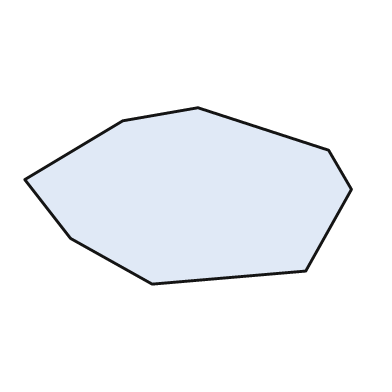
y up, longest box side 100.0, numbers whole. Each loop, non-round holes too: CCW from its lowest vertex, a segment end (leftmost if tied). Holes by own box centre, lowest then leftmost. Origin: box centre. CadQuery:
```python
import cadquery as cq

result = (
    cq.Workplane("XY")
    .moveTo(-11.0, -27.0)
    .lineTo(36.0, -23.0)
    .lineTo(50.0, 2.0)
    .lineTo(43.0, 14.0)
    .lineTo(3.0, 27.0)
    .lineTo(-20.0, 23.0)
    .lineTo(-50.0, 5.0)
    .lineTo(-36.0, -13.0)
    .close()
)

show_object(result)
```